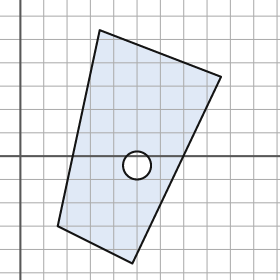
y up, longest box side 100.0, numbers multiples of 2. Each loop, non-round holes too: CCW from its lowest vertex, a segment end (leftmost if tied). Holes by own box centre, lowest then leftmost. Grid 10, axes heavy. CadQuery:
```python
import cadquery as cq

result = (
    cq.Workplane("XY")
    .moveTo(48.0, -46.0)
    .lineTo(86.0, 34.0)
    .lineTo(34.0, 54.0)
    .lineTo(16.0, -30.0)
    .close()
    .moveTo(50.0, -4.0)
    .circle(6.0)
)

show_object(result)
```